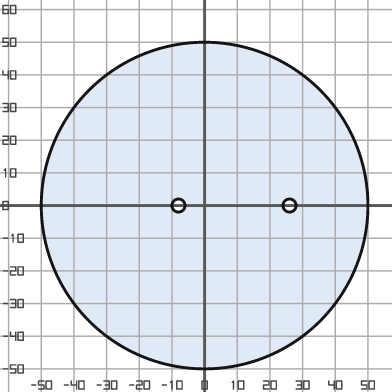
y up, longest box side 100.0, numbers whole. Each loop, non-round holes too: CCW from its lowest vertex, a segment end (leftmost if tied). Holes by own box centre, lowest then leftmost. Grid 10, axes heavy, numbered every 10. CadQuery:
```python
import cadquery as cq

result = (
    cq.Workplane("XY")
    .moveTo(0.0, 0.0)
    .circle(50.0)
    .moveTo(-8.0, 0.0)
    .circle(2.0)
    .moveTo(26.0, 0.0)
    .circle(2.0)
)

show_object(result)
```